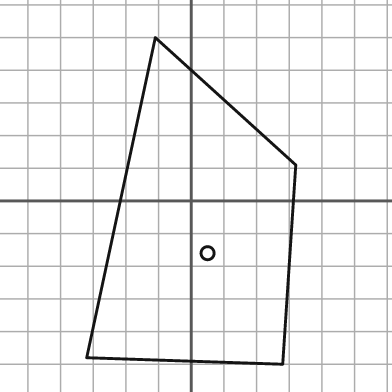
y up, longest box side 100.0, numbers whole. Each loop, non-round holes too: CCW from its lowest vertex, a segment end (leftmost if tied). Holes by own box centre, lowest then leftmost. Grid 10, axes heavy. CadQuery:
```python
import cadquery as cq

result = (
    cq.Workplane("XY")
    .moveTo(28.0, -50.0)
    .lineTo(32.0, 11.0)
    .lineTo(-11.0, 50.0)
    .lineTo(-32.0, -48.0)
    .close()
    .moveTo(5.0, -16.0)
    .circle(2.0)
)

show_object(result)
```